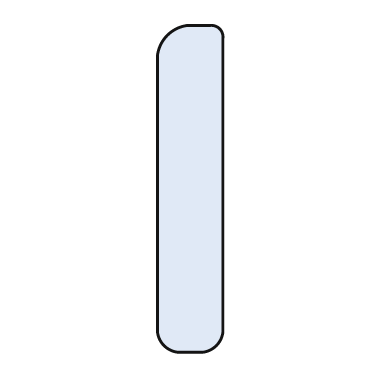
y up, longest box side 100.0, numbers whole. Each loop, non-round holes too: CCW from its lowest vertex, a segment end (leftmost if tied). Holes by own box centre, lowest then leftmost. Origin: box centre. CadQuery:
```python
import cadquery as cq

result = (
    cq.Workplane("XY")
    .moveTo(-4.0, -50.0)
    .lineTo(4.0, -50.0)
    .threePointArc((8.0, -48.0), (10.0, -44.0))
    .lineTo(10.0, 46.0)
    .threePointArc((9.0, 49.0), (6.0, 50.0))
    .lineTo(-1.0, 50.0)
    .threePointArc((-7.0, 47.0), (-10.0, 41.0))
    .lineTo(-10.0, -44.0)
    .threePointArc((-8.0, -48.0), (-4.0, -50.0))
    .close()
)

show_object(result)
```